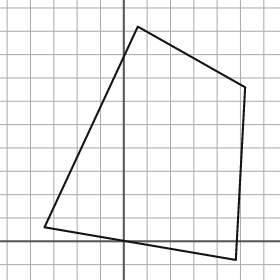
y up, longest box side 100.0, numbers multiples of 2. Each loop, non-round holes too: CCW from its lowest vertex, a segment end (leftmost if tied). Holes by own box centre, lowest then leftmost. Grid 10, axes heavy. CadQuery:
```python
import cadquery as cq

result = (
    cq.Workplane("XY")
    .moveTo(48.0, -8.0)
    .lineTo(52.0, 66.0)
    .lineTo(6.0, 92.0)
    .lineTo(-34.0, 6.0)
    .close()
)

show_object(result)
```